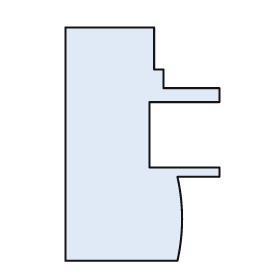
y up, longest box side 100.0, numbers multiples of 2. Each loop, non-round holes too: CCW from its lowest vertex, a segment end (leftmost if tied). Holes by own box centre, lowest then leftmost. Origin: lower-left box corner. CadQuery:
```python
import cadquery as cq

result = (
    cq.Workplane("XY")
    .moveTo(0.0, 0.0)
    .lineTo(48.0, 0.0)
    .threePointArc((50.0, 18.0), (48.0, 36.0))
    .lineTo(66.0, 36.0)
    .lineTo(66.0, 40.0)
    .lineTo(36.0, 40.0)
    .lineTo(36.0, 68.0)
    .lineTo(66.0, 68.0)
    .lineTo(66.0, 74.0)
    .lineTo(42.0, 74.0)
    .lineTo(42.0, 82.0)
    .lineTo(38.0, 82.0)
    .lineTo(38.0, 100.0)
    .lineTo(0.0, 100.0)
    .close()
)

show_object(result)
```